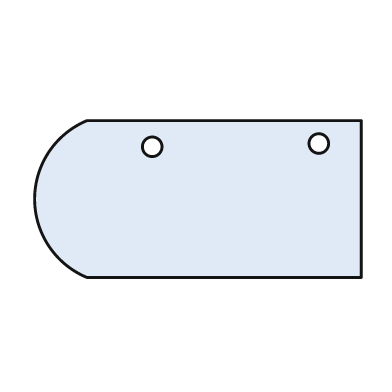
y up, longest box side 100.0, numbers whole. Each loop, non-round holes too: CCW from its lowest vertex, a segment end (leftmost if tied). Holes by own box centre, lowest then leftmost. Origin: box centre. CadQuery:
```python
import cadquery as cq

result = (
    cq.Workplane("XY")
    .moveTo(-34.0, -24.0)
    .lineTo(50.0, -24.0)
    .lineTo(50.0, 24.0)
    .lineTo(-34.0, 24.0)
    .threePointArc((-50.0, 0.0), (-34.0, -24.0))
    .close()
    .moveTo(-14.0, 16.0)
    .circle(3.0)
    .moveTo(37.0, 17.0)
    .circle(3.0)
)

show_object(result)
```